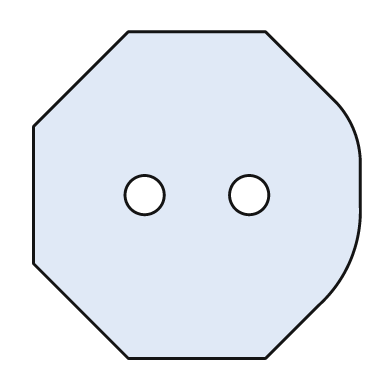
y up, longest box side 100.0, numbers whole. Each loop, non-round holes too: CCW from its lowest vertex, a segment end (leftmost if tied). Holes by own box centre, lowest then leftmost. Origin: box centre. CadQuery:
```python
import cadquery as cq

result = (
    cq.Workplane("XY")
    .moveTo(-21.0, -50.0)
    .lineTo(21.0, -50.0)
    .lineTo(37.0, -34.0)
    .threePointArc((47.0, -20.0), (50.0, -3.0))
    .lineTo(50.0, 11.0)
    .threePointArc((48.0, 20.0), (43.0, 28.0))
    .lineTo(21.0, 50.0)
    .lineTo(-21.0, 50.0)
    .lineTo(-50.0, 21.0)
    .lineTo(-50.0, -21.0)
    .close()
    .moveTo(-16.0, 0.0)
    .circle(6.0)
    .moveTo(16.0, 0.0)
    .circle(6.0)
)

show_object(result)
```